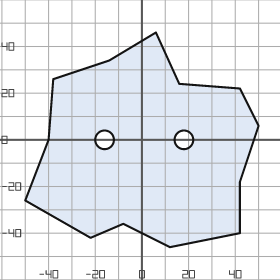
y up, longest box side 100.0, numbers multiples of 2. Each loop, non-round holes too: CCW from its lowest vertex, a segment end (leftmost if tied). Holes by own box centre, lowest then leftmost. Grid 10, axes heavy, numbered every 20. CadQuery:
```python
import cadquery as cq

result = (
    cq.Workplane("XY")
    .moveTo(12.0, -46.0)
    .lineTo(42.0, -40.0)
    .lineTo(42.0, -18.0)
    .lineTo(50.0, 6.0)
    .lineTo(42.0, 22.0)
    .lineTo(16.0, 24.0)
    .lineTo(6.0, 46.0)
    .lineTo(-14.0, 34.0)
    .lineTo(-38.0, 26.0)
    .lineTo(-40.0, 0.0)
    .lineTo(-50.0, -26.0)
    .lineTo(-22.0, -42.0)
    .lineTo(-8.0, -36.0)
    .close()
    .moveTo(-16.0, 0.0)
    .circle(4.0)
    .moveTo(18.0, 0.0)
    .circle(4.0)
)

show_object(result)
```